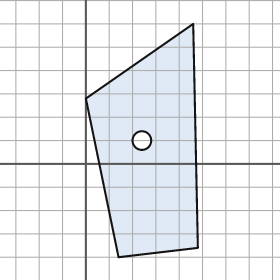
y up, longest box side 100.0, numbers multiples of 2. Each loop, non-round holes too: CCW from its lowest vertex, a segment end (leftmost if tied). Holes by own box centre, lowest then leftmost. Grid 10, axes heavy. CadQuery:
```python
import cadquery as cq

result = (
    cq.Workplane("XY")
    .moveTo(14.0, -40.0)
    .lineTo(48.0, -36.0)
    .lineTo(46.0, 60.0)
    .lineTo(0.0, 28.0)
    .close()
    .moveTo(24.0, 10.0)
    .circle(4.0)
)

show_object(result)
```